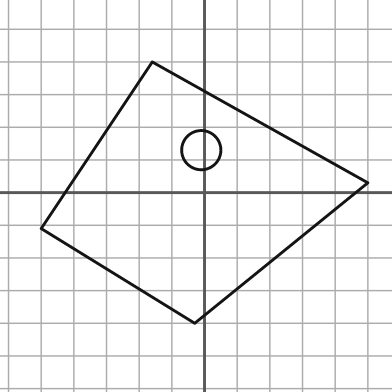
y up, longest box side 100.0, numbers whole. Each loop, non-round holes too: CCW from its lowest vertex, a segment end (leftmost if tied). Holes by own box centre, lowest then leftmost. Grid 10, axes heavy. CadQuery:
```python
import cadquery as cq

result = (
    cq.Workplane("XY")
    .moveTo(-3.0, -40.0)
    .lineTo(50.0, 3.0)
    .lineTo(-16.0, 40.0)
    .lineTo(-50.0, -11.0)
    .close()
    .moveTo(-1.0, 13.0)
    .circle(6.0)
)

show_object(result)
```